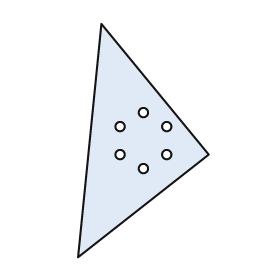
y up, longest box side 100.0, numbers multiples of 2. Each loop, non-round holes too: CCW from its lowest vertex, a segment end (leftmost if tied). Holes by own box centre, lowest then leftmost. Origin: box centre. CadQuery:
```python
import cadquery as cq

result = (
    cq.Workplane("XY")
    .moveTo(-28.0, -50.0)
    .lineTo(28.0, -6.0)
    .lineTo(-18.0, 50.0)
    .close()
    .moveTo(0.0, -12.0)
    .circle(2.0)
    .moveTo(-10.0, -6.0)
    .circle(2.0)
    .moveTo(10.0, -6.0)
    .circle(2.0)
    .moveTo(-10.0, 6.0)
    .circle(2.0)
    .moveTo(10.0, 6.0)
    .circle(2.0)
    .moveTo(0.0, 12.0)
    .circle(2.0)
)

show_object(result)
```